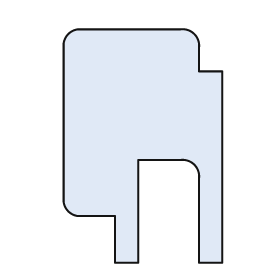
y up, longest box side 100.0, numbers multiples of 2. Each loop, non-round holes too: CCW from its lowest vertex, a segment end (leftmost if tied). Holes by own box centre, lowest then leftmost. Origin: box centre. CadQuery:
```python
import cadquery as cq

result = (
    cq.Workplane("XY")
    .moveTo(-12.0, -50.0)
    .lineTo(-2.0, -50.0)
    .lineTo(-2.0, -6.0)
    .lineTo(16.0, -6.0)
    .threePointArc((22.0, -8.0), (24.0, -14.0))
    .lineTo(24.0, -50.0)
    .lineTo(34.0, -50.0)
    .lineTo(34.0, 32.0)
    .lineTo(24.0, 32.0)
    .lineTo(24.0, 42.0)
    .threePointArc((22.0, 48.0), (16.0, 50.0))
    .lineTo(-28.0, 50.0)
    .threePointArc((-32.0, 48.0), (-34.0, 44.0))
    .lineTo(-34.0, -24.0)
    .threePointArc((-32.0, -28.0), (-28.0, -30.0))
    .lineTo(-12.0, -30.0)
    .close()
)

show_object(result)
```